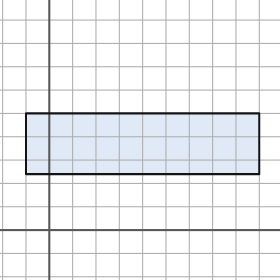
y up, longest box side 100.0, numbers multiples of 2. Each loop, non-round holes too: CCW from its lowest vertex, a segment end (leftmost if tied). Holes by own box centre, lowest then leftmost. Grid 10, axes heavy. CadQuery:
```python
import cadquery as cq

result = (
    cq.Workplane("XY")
    .moveTo(-10.0, 24.0)
    .lineTo(90.0, 24.0)
    .lineTo(90.0, 50.0)
    .lineTo(-10.0, 50.0)
    .close()
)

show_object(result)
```